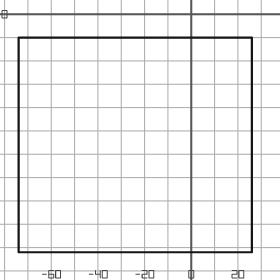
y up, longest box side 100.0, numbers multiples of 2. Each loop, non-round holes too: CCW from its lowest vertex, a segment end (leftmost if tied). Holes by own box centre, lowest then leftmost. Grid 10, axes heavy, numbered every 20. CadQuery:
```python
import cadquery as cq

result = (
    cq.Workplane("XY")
    .moveTo(-74.0, -102.0)
    .lineTo(26.0, -102.0)
    .lineTo(26.0, -10.0)
    .lineTo(-74.0, -10.0)
    .close()
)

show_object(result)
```